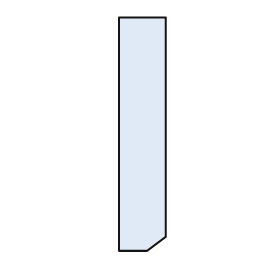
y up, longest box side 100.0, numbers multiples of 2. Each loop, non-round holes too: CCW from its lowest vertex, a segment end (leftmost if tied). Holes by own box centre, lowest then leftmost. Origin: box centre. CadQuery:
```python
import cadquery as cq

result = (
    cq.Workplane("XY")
    .moveTo(-10.0, -50.0)
    .lineTo(2.0, -50.0)
    .lineTo(10.0, -44.0)
    .lineTo(10.0, 50.0)
    .lineTo(-10.0, 50.0)
    .close()
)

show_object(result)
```